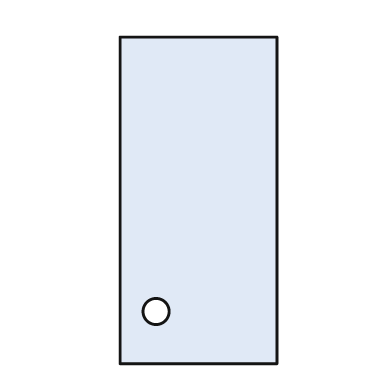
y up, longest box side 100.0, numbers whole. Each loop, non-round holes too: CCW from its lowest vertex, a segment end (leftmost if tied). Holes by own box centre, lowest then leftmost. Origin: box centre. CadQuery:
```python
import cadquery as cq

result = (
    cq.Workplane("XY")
    .moveTo(-24.0, -50.0)
    .lineTo(24.0, -50.0)
    .lineTo(24.0, 50.0)
    .lineTo(-24.0, 50.0)
    .close()
    .moveTo(-13.0, -34.0)
    .circle(4.0)
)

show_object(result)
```